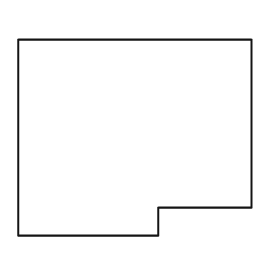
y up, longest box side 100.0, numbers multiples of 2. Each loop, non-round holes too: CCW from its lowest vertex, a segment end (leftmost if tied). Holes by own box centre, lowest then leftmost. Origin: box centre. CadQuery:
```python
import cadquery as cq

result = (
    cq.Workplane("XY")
    .moveTo(-50.0, -42.0)
    .lineTo(10.0, -42.0)
    .lineTo(10.0, -30.0)
    .lineTo(50.0, -30.0)
    .lineTo(50.0, 42.0)
    .lineTo(-50.0, 42.0)
    .close()
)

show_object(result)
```